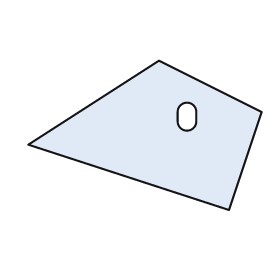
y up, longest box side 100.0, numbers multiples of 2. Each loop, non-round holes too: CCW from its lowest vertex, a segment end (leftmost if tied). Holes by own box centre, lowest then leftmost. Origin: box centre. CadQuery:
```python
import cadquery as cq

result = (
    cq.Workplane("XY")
    .moveTo(36.0, -32.0)
    .lineTo(50.0, 10.0)
    .lineTo(6.0, 32.0)
    .lineTo(-50.0, -4.0)
    .close()
    .moveTo(14.0, 6.0)
    .threePointArc((18.0, 2.0), (22.0, 6.0))
    .lineTo(22.0, 10.0)
    .threePointArc((18.0, 14.0), (14.0, 10.0))
    .close()
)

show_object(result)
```